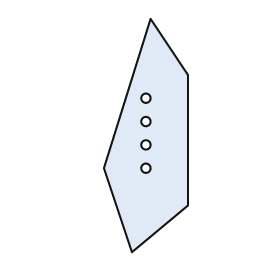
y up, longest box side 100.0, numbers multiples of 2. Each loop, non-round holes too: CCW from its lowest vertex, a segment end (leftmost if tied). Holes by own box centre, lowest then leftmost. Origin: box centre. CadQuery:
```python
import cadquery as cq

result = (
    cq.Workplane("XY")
    .moveTo(-6.0, -50.0)
    .lineTo(18.0, -30.0)
    .lineTo(18.0, 26.0)
    .lineTo(2.0, 50.0)
    .lineTo(-18.0, -14.0)
    .close()
    .moveTo(0.0, -14.0)
    .circle(2.0)
    .moveTo(0.0, -4.0)
    .circle(2.0)
    .moveTo(0.0, 6.0)
    .circle(2.0)
    .moveTo(0.0, 16.0)
    .circle(2.0)
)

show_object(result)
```